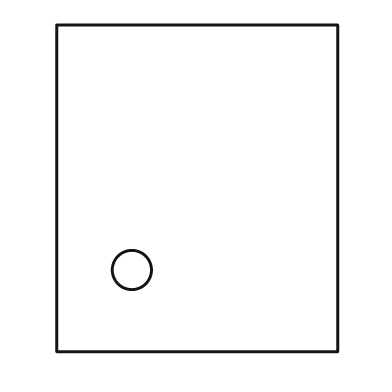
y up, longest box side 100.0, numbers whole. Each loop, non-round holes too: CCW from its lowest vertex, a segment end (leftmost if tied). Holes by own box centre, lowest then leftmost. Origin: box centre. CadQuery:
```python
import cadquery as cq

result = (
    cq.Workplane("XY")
    .moveTo(-43.0, -50.0)
    .lineTo(43.0, -50.0)
    .lineTo(43.0, 50.0)
    .lineTo(-43.0, 50.0)
    .close()
    .moveTo(-20.0, -25.0)
    .circle(6.0)
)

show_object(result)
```